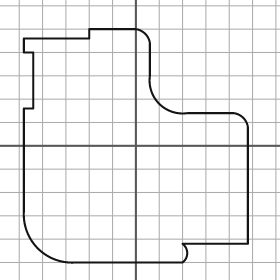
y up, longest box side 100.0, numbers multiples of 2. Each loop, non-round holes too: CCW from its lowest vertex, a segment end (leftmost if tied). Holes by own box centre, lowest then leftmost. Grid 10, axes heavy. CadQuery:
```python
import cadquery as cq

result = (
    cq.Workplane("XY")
    .moveTo(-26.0, -50.0)
    .lineTo(20.0, -50.0)
    .threePointArc((22.0, -46.0), (20.0, -42.0))
    .lineTo(48.0, -42.0)
    .lineTo(48.0, 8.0)
    .threePointArc((46.0, 12.0), (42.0, 14.0))
    .lineTo(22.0, 14.0)
    .threePointArc((10.0, 18.0), (6.0, 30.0))
    .lineTo(6.0, 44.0)
    .threePointArc((4.0, 48.0), (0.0, 50.0))
    .lineTo(-20.0, 50.0)
    .lineTo(-20.0, 46.0)
    .lineTo(-48.0, 46.0)
    .lineTo(-48.0, 40.0)
    .lineTo(-44.0, 40.0)
    .lineTo(-44.0, 16.0)
    .lineTo(-48.0, 16.0)
    .lineTo(-48.0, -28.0)
    .threePointArc((-42.0, -44.0), (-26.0, -50.0))
    .close()
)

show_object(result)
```